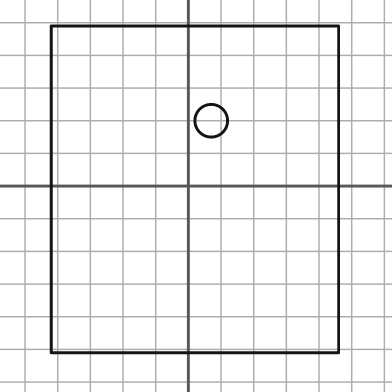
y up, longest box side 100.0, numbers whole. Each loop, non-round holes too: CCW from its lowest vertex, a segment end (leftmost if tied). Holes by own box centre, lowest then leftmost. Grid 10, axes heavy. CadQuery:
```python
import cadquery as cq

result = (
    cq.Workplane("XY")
    .moveTo(-42.0, -51.0)
    .lineTo(46.0, -51.0)
    .lineTo(46.0, 49.0)
    .lineTo(-42.0, 49.0)
    .close()
    .moveTo(7.0, 20.0)
    .circle(5.0)
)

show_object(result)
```